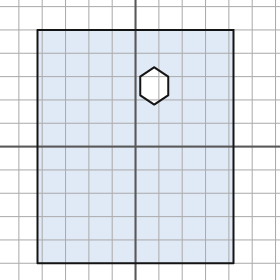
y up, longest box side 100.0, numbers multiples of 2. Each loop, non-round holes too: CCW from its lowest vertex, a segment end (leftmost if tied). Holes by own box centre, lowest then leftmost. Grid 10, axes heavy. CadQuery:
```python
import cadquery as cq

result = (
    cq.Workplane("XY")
    .moveTo(-42.0, -50.0)
    .lineTo(42.0, -50.0)
    .lineTo(42.0, 50.0)
    .lineTo(-42.0, 50.0)
    .close()
    .moveTo(8.0, 18.0)
    .lineTo(14.0, 22.0)
    .lineTo(14.0, 30.0)
    .lineTo(8.0, 34.0)
    .lineTo(2.0, 30.0)
    .lineTo(2.0, 22.0)
    .close()
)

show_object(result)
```